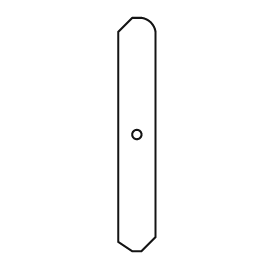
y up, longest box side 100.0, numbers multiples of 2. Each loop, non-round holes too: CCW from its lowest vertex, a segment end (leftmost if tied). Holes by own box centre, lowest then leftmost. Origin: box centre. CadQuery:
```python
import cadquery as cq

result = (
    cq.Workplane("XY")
    .moveTo(-2.0, -50.0)
    .lineTo(2.0, -50.0)
    .lineTo(8.0, -44.0)
    .lineTo(8.0, 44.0)
    .threePointArc((6.0, 48.0), (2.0, 50.0))
    .lineTo(-2.0, 50.0)
    .lineTo(-8.0, 44.0)
    .lineTo(-8.0, -46.0)
    .close()
    .moveTo(0.0, 0.0)
    .circle(2.0)
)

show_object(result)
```